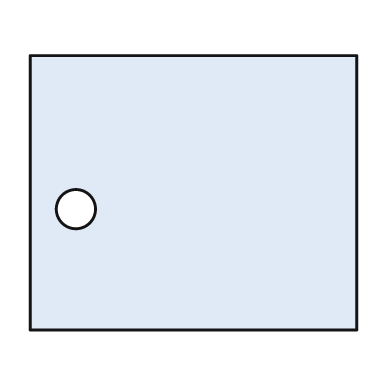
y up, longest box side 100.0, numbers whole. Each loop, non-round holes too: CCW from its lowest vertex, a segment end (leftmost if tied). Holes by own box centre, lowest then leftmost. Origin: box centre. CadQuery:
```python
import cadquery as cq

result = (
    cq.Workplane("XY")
    .moveTo(-50.0, -42.0)
    .lineTo(50.0, -42.0)
    .lineTo(50.0, 42.0)
    .lineTo(-50.0, 42.0)
    .close()
    .moveTo(-36.0, -5.0)
    .circle(6.0)
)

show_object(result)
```